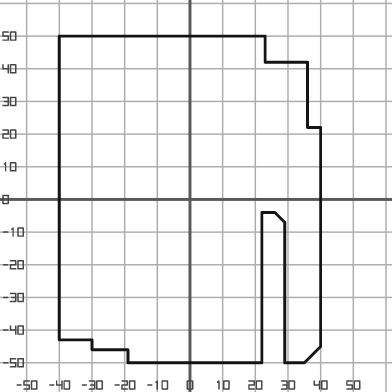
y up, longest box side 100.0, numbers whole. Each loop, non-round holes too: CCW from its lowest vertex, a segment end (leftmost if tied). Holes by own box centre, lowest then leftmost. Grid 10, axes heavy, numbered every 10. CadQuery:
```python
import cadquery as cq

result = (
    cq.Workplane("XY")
    .moveTo(-19.0, -50.0)
    .lineTo(22.0, -50.0)
    .lineTo(22.0, -4.0)
    .lineTo(26.0, -4.0)
    .lineTo(29.0, -7.0)
    .lineTo(29.0, -50.0)
    .lineTo(35.0, -50.0)
    .lineTo(40.0, -45.0)
    .lineTo(40.0, 22.0)
    .lineTo(36.0, 22.0)
    .lineTo(36.0, 42.0)
    .lineTo(23.0, 42.0)
    .lineTo(23.0, 50.0)
    .lineTo(-40.0, 50.0)
    .lineTo(-40.0, -43.0)
    .lineTo(-30.0, -43.0)
    .lineTo(-30.0, -46.0)
    .lineTo(-19.0, -46.0)
    .close()
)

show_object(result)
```